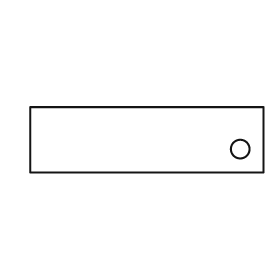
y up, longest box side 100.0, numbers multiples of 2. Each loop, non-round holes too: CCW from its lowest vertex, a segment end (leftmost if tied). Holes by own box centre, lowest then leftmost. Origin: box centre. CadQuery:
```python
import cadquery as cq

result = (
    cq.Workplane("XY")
    .moveTo(-50.0, -14.0)
    .lineTo(50.0, -14.0)
    .lineTo(50.0, 14.0)
    .lineTo(-50.0, 14.0)
    .close()
    .moveTo(40.0, -4.0)
    .circle(4.0)
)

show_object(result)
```